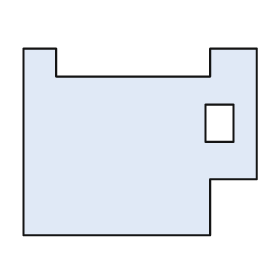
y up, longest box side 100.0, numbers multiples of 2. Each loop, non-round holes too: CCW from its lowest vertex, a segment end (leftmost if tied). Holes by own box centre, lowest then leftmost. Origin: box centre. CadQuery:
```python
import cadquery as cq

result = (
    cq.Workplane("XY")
    .moveTo(-50.0, -40.0)
    .lineTo(30.0, -40.0)
    .lineTo(30.0, -16.0)
    .lineTo(50.0, -16.0)
    .lineTo(50.0, 40.0)
    .lineTo(30.0, 40.0)
    .lineTo(30.0, 28.0)
    .lineTo(-36.0, 28.0)
    .lineTo(-36.0, 40.0)
    .lineTo(-50.0, 40.0)
    .close()
    .moveTo(28.0, 0.0)
    .lineTo(40.0, 0.0)
    .lineTo(40.0, 16.0)
    .lineTo(28.0, 16.0)
    .close()
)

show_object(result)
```